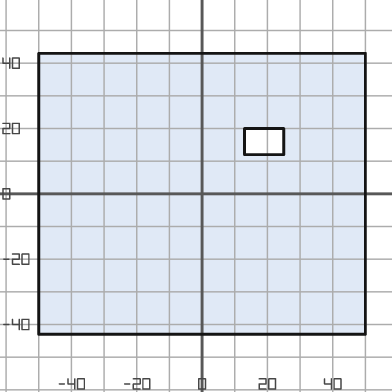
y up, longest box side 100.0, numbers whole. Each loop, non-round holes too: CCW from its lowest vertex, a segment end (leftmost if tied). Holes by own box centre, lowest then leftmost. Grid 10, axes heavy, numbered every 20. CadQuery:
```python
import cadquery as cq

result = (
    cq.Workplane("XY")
    .moveTo(-50.0, -43.0)
    .lineTo(50.0, -43.0)
    .lineTo(50.0, 43.0)
    .lineTo(-50.0, 43.0)
    .close()
    .moveTo(13.0, 12.0)
    .lineTo(25.0, 12.0)
    .lineTo(25.0, 20.0)
    .lineTo(13.0, 20.0)
    .close()
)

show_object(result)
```